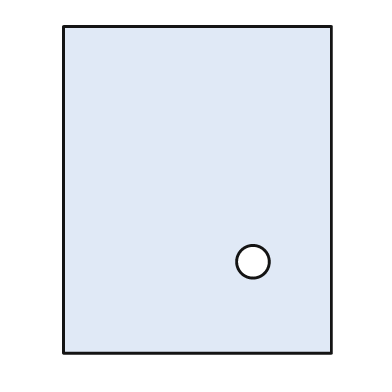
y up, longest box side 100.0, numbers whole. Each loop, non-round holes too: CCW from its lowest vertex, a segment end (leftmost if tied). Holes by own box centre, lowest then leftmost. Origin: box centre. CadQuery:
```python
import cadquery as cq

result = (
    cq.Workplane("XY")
    .moveTo(-41.0, -50.0)
    .lineTo(41.0, -50.0)
    .lineTo(41.0, 50.0)
    .lineTo(-41.0, 50.0)
    .close()
    .moveTo(17.0, -22.0)
    .circle(5.0)
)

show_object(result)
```